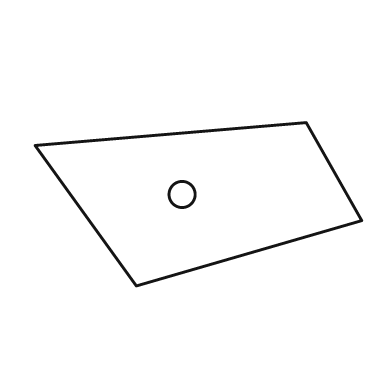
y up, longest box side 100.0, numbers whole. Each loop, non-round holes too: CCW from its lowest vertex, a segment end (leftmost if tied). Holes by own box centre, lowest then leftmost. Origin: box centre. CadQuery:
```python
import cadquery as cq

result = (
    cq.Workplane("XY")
    .moveTo(-19.0, -25.0)
    .lineTo(50.0, -5.0)
    .lineTo(33.0, 25.0)
    .lineTo(-50.0, 18.0)
    .close()
    .moveTo(-5.0, 3.0)
    .circle(4.0)
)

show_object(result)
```